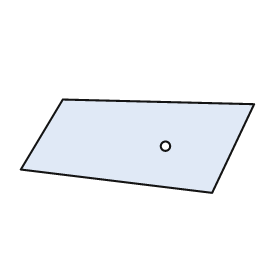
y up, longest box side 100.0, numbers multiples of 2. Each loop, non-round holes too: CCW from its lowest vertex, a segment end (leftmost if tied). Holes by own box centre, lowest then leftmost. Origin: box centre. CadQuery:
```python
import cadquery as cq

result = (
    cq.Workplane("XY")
    .moveTo(32.0, -20.0)
    .lineTo(50.0, 18.0)
    .lineTo(-32.0, 20.0)
    .lineTo(-50.0, -10.0)
    .close()
    .moveTo(12.0, 0.0)
    .circle(2.0)
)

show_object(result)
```